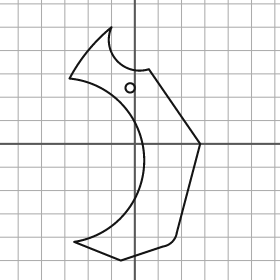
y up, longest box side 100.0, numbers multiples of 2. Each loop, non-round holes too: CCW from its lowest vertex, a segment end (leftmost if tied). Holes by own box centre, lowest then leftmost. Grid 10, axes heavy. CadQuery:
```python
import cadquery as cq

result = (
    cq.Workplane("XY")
    .moveTo(-6.0, -50.0)
    .lineTo(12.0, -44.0)
    .threePointArc((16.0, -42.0), (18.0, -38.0))
    .lineTo(28.0, 0.0)
    .lineTo(6.0, 32.0)
    .threePointArc((-8.0, 36.0), (-10.0, 50.0))
    .threePointArc((-20.0, 40.0), (-28.0, 28.0))
    .threePointArc((4.0, -6.0), (-26.0, -42.0))
    .close()
    .moveTo(-2.0, 24.0)
    .circle(2.0)
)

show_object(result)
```